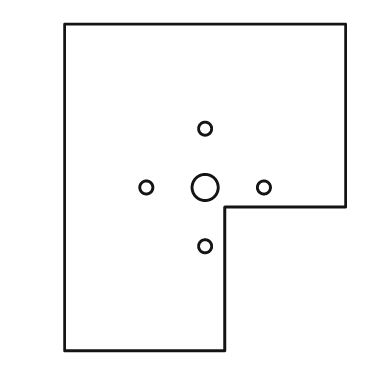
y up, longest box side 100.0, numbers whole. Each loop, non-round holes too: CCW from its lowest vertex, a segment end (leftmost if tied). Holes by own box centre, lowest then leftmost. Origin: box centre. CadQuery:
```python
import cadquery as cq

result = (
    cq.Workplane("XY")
    .moveTo(-43.0, -50.0)
    .lineTo(6.0, -50.0)
    .lineTo(6.0, -6.0)
    .lineTo(43.0, -6.0)
    .lineTo(43.0, 50.0)
    .lineTo(-43.0, 50.0)
    .close()
    .moveTo(0.0, -18.0)
    .circle(2.0)
    .moveTo(-18.0, 0.0)
    .circle(2.0)
    .moveTo(0.0, 0.0)
    .circle(4.0)
    .moveTo(18.0, 0.0)
    .circle(2.0)
    .moveTo(0.0, 18.0)
    .circle(2.0)
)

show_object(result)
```